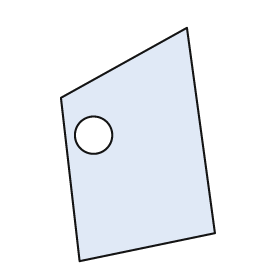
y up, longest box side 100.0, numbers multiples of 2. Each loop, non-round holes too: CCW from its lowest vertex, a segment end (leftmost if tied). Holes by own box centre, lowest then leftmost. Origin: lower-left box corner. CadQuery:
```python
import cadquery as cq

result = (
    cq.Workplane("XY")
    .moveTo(8.0, 0.0)
    .lineTo(66.0, 12.0)
    .lineTo(54.0, 100.0)
    .lineTo(0.0, 70.0)
    .close()
    .moveTo(14.0, 54.0)
    .circle(8.0)
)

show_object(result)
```